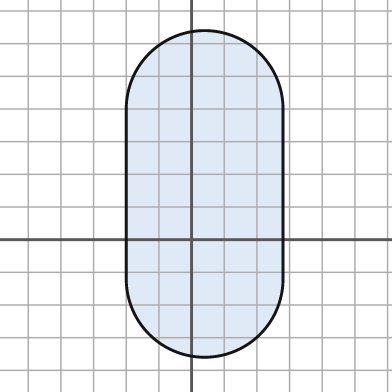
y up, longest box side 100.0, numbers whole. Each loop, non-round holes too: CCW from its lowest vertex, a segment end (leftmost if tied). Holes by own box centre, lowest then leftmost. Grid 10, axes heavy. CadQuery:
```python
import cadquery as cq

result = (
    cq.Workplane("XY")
    .moveTo(-20.0, -12.0)
    .threePointArc((4.0, -36.0), (28.0, -12.0))
    .lineTo(28.0, 40.0)
    .threePointArc((4.0, 64.0), (-20.0, 40.0))
    .close()
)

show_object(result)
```